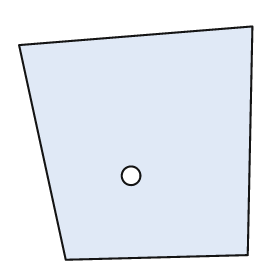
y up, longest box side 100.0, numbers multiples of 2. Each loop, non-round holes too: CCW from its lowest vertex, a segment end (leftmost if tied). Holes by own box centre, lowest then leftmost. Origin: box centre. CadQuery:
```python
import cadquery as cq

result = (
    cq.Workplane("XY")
    .moveTo(-30.0, -50.0)
    .lineTo(48.0, -48.0)
    .lineTo(50.0, 50.0)
    .lineTo(-50.0, 42.0)
    .close()
    .moveTo(-2.0, -14.0)
    .circle(4.0)
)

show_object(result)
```